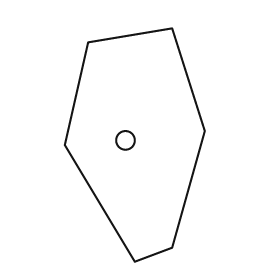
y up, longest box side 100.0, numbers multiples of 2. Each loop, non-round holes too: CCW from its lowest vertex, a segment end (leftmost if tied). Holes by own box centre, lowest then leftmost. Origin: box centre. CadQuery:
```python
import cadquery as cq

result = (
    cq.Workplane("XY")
    .moveTo(0.0, -50.0)
    .lineTo(16.0, -44.0)
    .lineTo(30.0, 6.0)
    .lineTo(16.0, 50.0)
    .lineTo(-20.0, 44.0)
    .lineTo(-30.0, 0.0)
    .close()
    .moveTo(-4.0, 2.0)
    .circle(4.0)
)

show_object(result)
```